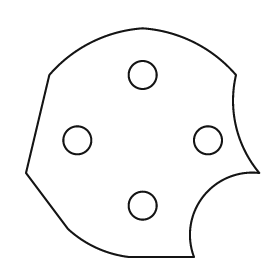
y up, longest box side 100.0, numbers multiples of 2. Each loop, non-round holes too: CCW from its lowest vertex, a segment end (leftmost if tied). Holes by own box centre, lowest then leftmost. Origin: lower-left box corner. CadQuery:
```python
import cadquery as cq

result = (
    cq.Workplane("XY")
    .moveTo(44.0, 0.0)
    .lineTo(72.0, 0.0)
    .threePointArc((76.0, 26.0), (100.0, 36.0))
    .threePointArc((90.0, 56.0), (90.0, 78.0))
    .threePointArc((72.0, 92.0), (50.0, 98.0))
    .threePointArc((28.0, 92.0), (10.0, 78.0))
    .lineTo(0.0, 36.0)
    .lineTo(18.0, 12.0)
    .threePointArc((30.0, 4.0), (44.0, 0.0))
    .close()
    .moveTo(50.0, 22.0)
    .circle(6.0)
    .moveTo(22.0, 50.0)
    .circle(6.0)
    .moveTo(78.0, 50.0)
    .circle(6.0)
    .moveTo(50.0, 78.0)
    .circle(6.0)
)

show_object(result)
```